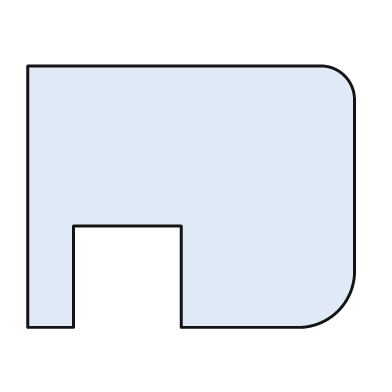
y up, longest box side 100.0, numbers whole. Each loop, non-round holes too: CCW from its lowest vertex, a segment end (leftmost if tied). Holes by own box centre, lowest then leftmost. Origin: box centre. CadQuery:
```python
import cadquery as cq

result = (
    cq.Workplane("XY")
    .moveTo(-50.0, -40.0)
    .lineTo(-36.0, -40.0)
    .lineTo(-36.0, -9.0)
    .lineTo(-3.0, -9.0)
    .lineTo(-3.0, -40.0)
    .lineTo(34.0, -40.0)
    .threePointArc((45.0, -35.0), (50.0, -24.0))
    .lineTo(50.0, 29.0)
    .threePointArc((47.0, 37.0), (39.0, 40.0))
    .lineTo(-50.0, 40.0)
    .close()
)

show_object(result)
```